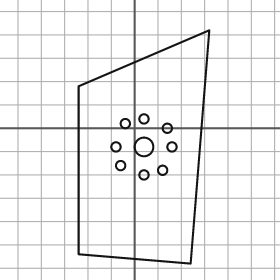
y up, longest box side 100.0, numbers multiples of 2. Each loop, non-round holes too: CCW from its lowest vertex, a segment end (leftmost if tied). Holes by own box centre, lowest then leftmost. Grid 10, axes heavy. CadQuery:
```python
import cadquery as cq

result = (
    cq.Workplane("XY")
    .moveTo(24.0, -58.0)
    .lineTo(32.0, 42.0)
    .lineTo(-24.0, 18.0)
    .lineTo(-24.0, -54.0)
    .close()
    .moveTo(4.0, -20.0)
    .circle(2.0)
    .moveTo(12.0, -18.0)
    .circle(2.0)
    .moveTo(-6.0, -16.0)
    .circle(2.0)
    .moveTo(-8.0, -8.0)
    .circle(2.0)
    .moveTo(4.0, -8.0)
    .circle(4.0)
    .moveTo(16.0, -8.0)
    .circle(2.0)
    .moveTo(14.0, 0.0)
    .circle(2.0)
    .moveTo(-4.0, 2.0)
    .circle(2.0)
    .moveTo(4.0, 4.0)
    .circle(2.0)
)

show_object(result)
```